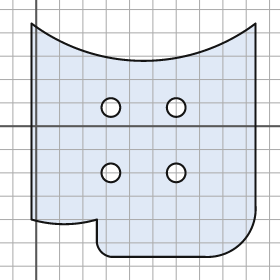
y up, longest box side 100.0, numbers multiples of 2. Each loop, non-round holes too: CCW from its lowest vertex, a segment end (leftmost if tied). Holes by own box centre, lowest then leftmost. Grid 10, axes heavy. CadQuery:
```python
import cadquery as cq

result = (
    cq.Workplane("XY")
    .moveTo(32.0, -56.0)
    .lineTo(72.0, -56.0)
    .threePointArc((88.0, -50.0), (94.0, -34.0))
    .lineTo(94.0, 44.0)
    .threePointArc((46.0, 28.0), (-2.0, 44.0))
    .lineTo(-2.0, -40.0)
    .threePointArc((12.0, -42.0), (26.0, -40.0))
    .lineTo(26.0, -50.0)
    .threePointArc((28.0, -54.0), (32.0, -56.0))
    .close()
    .moveTo(32.0, -20.0)
    .circle(4.0)
    .moveTo(60.0, -20.0)
    .circle(4.0)
    .moveTo(32.0, 8.0)
    .circle(4.0)
    .moveTo(60.0, 8.0)
    .circle(4.0)
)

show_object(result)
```